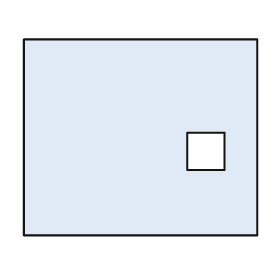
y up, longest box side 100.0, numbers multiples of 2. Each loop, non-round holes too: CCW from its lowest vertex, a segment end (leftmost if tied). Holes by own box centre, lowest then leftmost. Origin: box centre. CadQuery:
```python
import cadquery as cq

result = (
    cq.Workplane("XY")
    .moveTo(-50.0, -42.0)
    .lineTo(50.0, -42.0)
    .lineTo(50.0, 42.0)
    .lineTo(-50.0, 42.0)
    .close()
    .moveTo(20.0, -14.0)
    .lineTo(36.0, -14.0)
    .lineTo(36.0, 2.0)
    .lineTo(20.0, 2.0)
    .close()
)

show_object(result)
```